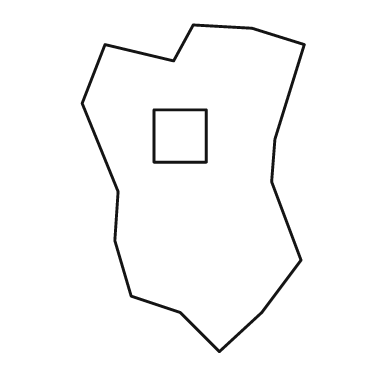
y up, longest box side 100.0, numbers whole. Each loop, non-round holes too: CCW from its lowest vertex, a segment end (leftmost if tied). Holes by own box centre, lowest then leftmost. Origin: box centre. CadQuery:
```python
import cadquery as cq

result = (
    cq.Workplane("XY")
    .moveTo(8.0, -50.0)
    .lineTo(21.0, -38.0)
    .lineTo(33.0, -22.0)
    .lineTo(24.0, 2.0)
    .lineTo(25.0, 15.0)
    .lineTo(34.0, 44.0)
    .lineTo(18.0, 49.0)
    .lineTo(0.0, 50.0)
    .lineTo(-6.0, 39.0)
    .lineTo(-27.0, 44.0)
    .lineTo(-34.0, 26.0)
    .lineTo(-23.0, -1.0)
    .lineTo(-24.0, -16.0)
    .lineTo(-19.0, -33.0)
    .lineTo(-4.0, -38.0)
    .close()
    .moveTo(-12.0, 8.0)
    .lineTo(4.0, 8.0)
    .lineTo(4.0, 24.0)
    .lineTo(-12.0, 24.0)
    .close()
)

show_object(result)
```